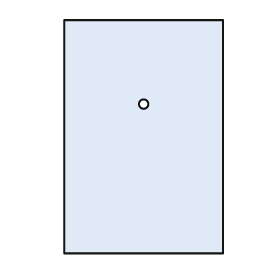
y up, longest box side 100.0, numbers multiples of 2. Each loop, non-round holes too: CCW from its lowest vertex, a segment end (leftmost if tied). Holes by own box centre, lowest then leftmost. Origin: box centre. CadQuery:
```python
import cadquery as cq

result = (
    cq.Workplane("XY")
    .moveTo(-34.0, -50.0)
    .lineTo(34.0, -50.0)
    .lineTo(34.0, 50.0)
    .lineTo(-34.0, 50.0)
    .close()
    .moveTo(0.0, 14.0)
    .circle(2.0)
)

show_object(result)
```